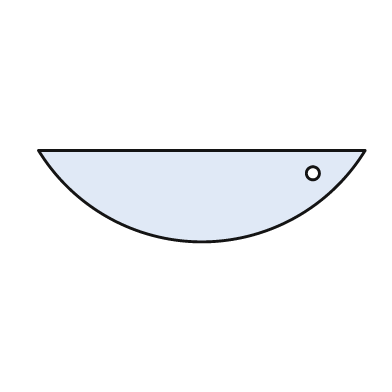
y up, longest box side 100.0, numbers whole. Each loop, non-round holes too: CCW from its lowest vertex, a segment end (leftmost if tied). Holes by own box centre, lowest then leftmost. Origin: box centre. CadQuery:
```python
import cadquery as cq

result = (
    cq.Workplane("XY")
    .moveTo(-50.0, 14.0)
    .threePointArc((0.0, -14.0), (50.0, 14.0))
    .close()
    .moveTo(34.0, 7.0)
    .circle(2.0)
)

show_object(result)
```